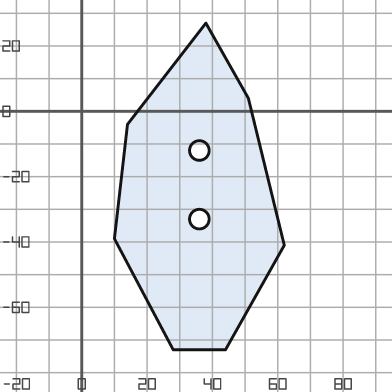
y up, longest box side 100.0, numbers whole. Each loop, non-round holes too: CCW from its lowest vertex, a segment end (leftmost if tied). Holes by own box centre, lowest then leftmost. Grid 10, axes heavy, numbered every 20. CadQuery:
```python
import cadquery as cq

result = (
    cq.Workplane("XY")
    .moveTo(28.0, -73.0)
    .lineTo(44.0, -73.0)
    .lineTo(62.0, -41.0)
    .lineTo(51.0, 4.0)
    .lineTo(38.0, 27.0)
    .lineTo(14.0, -4.0)
    .lineTo(10.0, -39.0)
    .close()
    .moveTo(36.0, -33.0)
    .circle(3.0)
    .moveTo(36.0, -12.0)
    .circle(3.0)
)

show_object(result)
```